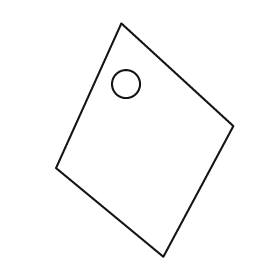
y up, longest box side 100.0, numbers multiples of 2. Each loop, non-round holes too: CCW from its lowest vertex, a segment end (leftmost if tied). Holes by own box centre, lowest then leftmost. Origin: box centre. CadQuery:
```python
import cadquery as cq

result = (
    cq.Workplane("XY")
    .moveTo(8.0, -50.0)
    .lineTo(38.0, 6.0)
    .lineTo(-10.0, 50.0)
    .lineTo(-38.0, -12.0)
    .close()
    .moveTo(-8.0, 24.0)
    .circle(6.0)
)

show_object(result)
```